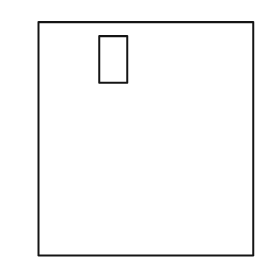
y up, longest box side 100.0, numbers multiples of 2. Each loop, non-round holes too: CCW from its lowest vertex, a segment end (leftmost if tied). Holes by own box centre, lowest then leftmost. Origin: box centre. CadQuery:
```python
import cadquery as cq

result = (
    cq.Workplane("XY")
    .moveTo(-46.0, -50.0)
    .lineTo(46.0, -50.0)
    .lineTo(46.0, 50.0)
    .lineTo(-46.0, 50.0)
    .close()
    .moveTo(-20.0, 24.0)
    .lineTo(-8.0, 24.0)
    .lineTo(-8.0, 44.0)
    .lineTo(-20.0, 44.0)
    .close()
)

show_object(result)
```